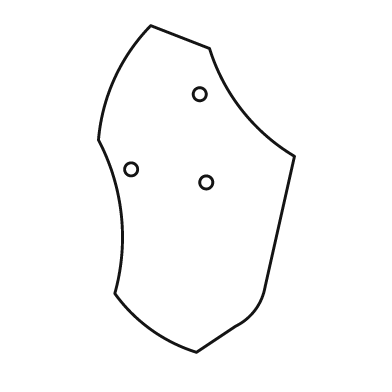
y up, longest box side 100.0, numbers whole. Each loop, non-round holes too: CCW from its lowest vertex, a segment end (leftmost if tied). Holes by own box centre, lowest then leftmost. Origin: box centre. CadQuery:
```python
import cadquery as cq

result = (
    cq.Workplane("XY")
    .moveTo(0.0, -50.0)
    .lineTo(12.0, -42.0)
    .threePointArc((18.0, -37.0), (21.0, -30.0))
    .lineTo(30.0, 10.0)
    .threePointArc((14.0, 24.0), (4.0, 43.0))
    .lineTo(-14.0, 50.0)
    .threePointArc((-25.0, 34.0), (-30.0, 15.0))
    .threePointArc((-23.0, -8.0), (-25.0, -32.0))
    .threePointArc((-14.0, -43.0), (0.0, -50.0))
    .close()
    .moveTo(3.0, 2.0)
    .circle(2.0)
    .moveTo(-20.0, 6.0)
    .circle(2.0)
    .moveTo(1.0, 29.0)
    .circle(2.0)
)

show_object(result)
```